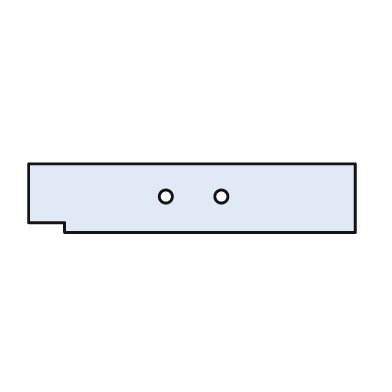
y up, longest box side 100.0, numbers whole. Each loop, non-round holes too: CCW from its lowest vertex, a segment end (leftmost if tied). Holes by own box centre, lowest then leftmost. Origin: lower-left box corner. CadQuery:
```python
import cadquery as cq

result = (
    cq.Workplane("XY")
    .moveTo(11.0, 0.0)
    .lineTo(100.0, 0.0)
    .lineTo(100.0, 21.0)
    .lineTo(0.0, 21.0)
    .lineTo(0.0, 3.0)
    .lineTo(11.0, 3.0)
    .close()
    .moveTo(42.0, 11.0)
    .circle(2.0)
    .moveTo(59.0, 11.0)
    .circle(2.0)
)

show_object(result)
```